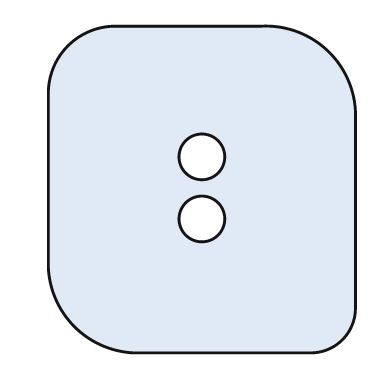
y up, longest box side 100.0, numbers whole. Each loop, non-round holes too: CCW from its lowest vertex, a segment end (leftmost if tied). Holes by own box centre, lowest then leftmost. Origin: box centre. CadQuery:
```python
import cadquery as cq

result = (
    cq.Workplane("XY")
    .moveTo(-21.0, -50.0)
    .lineTo(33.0, -50.0)
    .threePointArc((43.0, -46.0), (47.0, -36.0))
    .lineTo(47.0, 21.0)
    .threePointArc((39.0, 42.0), (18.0, 50.0))
    .lineTo(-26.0, 50.0)
    .threePointArc((-41.0, 44.0), (-47.0, 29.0))
    .lineTo(-47.0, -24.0)
    .threePointArc((-39.0, -42.0), (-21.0, -50.0))
    .close()
    .moveTo(0.0, -9.0)
    .circle(7.0)
    .moveTo(0.0, 10.0)
    .circle(7.0)
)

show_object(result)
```